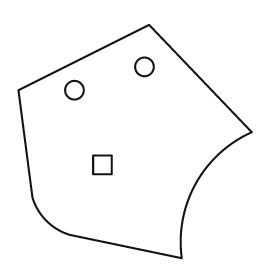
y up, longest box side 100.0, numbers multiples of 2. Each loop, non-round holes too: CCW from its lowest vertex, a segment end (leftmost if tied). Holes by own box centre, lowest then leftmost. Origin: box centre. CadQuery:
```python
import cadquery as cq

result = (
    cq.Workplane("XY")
    .moveTo(20.0, -50.0)
    .threePointArc((26.0, -18.0), (50.0, 4.0))
    .lineTo(6.0, 50.0)
    .lineTo(-50.0, 22.0)
    .lineTo(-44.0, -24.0)
    .threePointArc((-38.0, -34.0), (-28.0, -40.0))
    .close()
    .moveTo(-18.0, -14.0)
    .lineTo(-10.0, -14.0)
    .lineTo(-10.0, -6.0)
    .lineTo(-18.0, -6.0)
    .close()
    .moveTo(-26.0, 22.0)
    .circle(4.0)
    .moveTo(4.0, 32.0)
    .circle(4.0)
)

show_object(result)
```